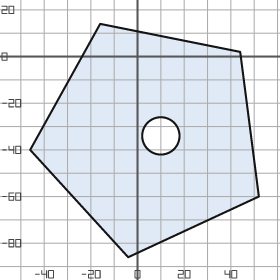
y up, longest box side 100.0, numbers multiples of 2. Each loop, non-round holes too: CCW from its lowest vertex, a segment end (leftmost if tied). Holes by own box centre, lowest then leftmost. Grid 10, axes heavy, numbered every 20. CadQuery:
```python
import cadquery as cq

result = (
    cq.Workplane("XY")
    .moveTo(-4.0, -86.0)
    .lineTo(52.0, -60.0)
    .lineTo(44.0, 2.0)
    .lineTo(-16.0, 14.0)
    .lineTo(-46.0, -40.0)
    .close()
    .moveTo(10.0, -34.0)
    .circle(8.0)
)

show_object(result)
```